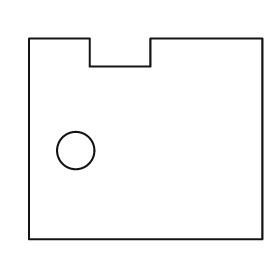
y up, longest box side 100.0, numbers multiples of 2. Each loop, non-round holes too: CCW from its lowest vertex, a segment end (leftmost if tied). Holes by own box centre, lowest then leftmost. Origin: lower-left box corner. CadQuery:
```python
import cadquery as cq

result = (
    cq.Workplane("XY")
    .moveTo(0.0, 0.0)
    .lineTo(100.0, 0.0)
    .lineTo(100.0, 86.0)
    .lineTo(52.0, 86.0)
    .lineTo(52.0, 74.0)
    .lineTo(26.0, 74.0)
    .lineTo(26.0, 86.0)
    .lineTo(0.0, 86.0)
    .close()
    .moveTo(20.0, 38.0)
    .circle(8.0)
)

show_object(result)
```